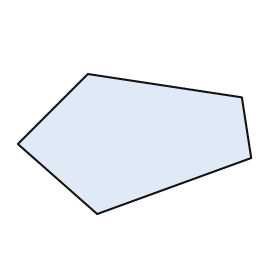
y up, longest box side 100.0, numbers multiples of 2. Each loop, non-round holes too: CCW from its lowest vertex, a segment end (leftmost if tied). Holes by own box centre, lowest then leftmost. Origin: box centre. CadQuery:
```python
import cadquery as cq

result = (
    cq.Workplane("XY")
    .moveTo(-16.0, -30.0)
    .lineTo(50.0, -6.0)
    .lineTo(46.0, 20.0)
    .lineTo(-20.0, 30.0)
    .lineTo(-50.0, 0.0)
    .close()
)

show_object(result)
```